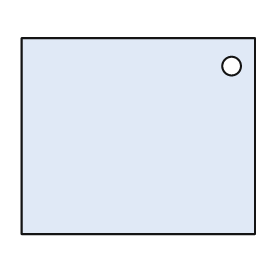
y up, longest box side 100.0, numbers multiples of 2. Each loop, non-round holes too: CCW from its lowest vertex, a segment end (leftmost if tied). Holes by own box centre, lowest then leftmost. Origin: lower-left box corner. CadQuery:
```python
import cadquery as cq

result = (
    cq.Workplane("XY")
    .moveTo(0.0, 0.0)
    .lineTo(100.0, 0.0)
    .lineTo(100.0, 84.0)
    .lineTo(0.0, 84.0)
    .close()
    .moveTo(90.0, 72.0)
    .circle(4.0)
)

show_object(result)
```